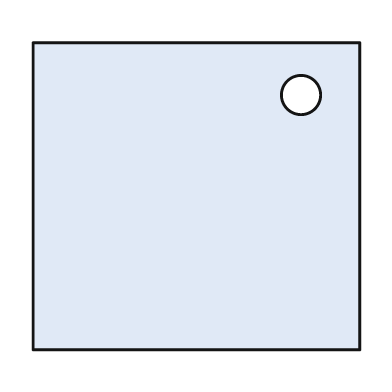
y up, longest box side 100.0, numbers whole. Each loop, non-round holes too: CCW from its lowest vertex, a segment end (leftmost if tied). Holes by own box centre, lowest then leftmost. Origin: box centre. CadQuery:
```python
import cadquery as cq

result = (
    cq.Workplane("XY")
    .moveTo(-50.0, -47.0)
    .lineTo(50.0, -47.0)
    .lineTo(50.0, 47.0)
    .lineTo(-50.0, 47.0)
    .close()
    .moveTo(32.0, 31.0)
    .circle(6.0)
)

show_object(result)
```